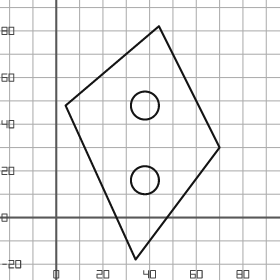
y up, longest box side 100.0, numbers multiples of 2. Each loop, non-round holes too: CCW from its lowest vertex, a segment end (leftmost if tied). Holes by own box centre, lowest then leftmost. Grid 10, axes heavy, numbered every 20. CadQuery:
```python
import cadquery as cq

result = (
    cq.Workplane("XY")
    .moveTo(34.0, -18.0)
    .lineTo(70.0, 30.0)
    .lineTo(44.0, 82.0)
    .lineTo(4.0, 48.0)
    .close()
    .moveTo(38.0, 16.0)
    .circle(6.0)
    .moveTo(38.0, 48.0)
    .circle(6.0)
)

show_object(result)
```